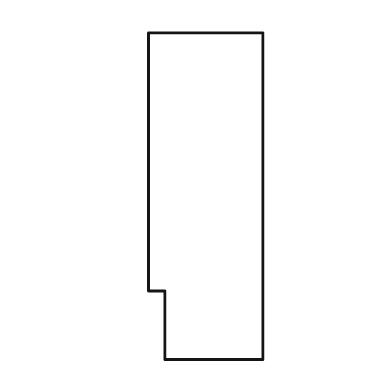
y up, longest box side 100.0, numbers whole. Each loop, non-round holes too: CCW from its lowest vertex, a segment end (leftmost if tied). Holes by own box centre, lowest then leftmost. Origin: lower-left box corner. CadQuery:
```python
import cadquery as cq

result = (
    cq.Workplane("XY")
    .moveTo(5.0, 0.0)
    .lineTo(35.0, 0.0)
    .lineTo(35.0, 100.0)
    .lineTo(0.0, 100.0)
    .lineTo(0.0, 21.0)
    .lineTo(5.0, 21.0)
    .close()
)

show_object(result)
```